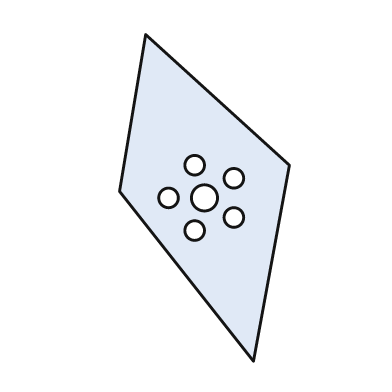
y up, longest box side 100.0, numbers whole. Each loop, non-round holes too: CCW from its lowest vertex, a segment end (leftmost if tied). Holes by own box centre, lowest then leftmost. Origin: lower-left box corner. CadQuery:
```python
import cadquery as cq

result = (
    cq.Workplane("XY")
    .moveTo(41.0, 0.0)
    .lineTo(52.0, 60.0)
    .lineTo(8.0, 100.0)
    .lineTo(0.0, 52.0)
    .close()
    .moveTo(23.0, 40.0)
    .circle(3.0)
    .moveTo(35.0, 44.0)
    .circle(3.0)
    .moveTo(15.0, 50.0)
    .circle(3.0)
    .moveTo(26.0, 50.0)
    .circle(4.0)
    .moveTo(35.0, 56.0)
    .circle(3.0)
    .moveTo(23.0, 60.0)
    .circle(3.0)
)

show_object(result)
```